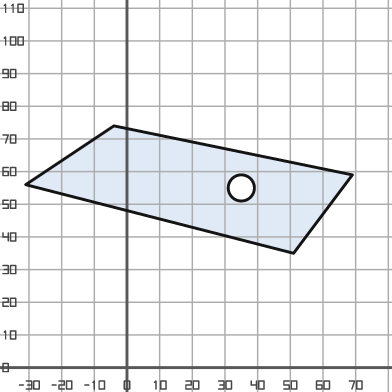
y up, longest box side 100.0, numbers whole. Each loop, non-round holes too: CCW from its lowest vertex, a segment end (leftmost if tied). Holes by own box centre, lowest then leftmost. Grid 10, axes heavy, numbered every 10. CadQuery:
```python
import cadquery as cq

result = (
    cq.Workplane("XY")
    .moveTo(51.0, 35.0)
    .lineTo(69.0, 59.0)
    .lineTo(-4.0, 74.0)
    .lineTo(-31.0, 56.0)
    .close()
    .moveTo(35.0, 55.0)
    .circle(4.0)
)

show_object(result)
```